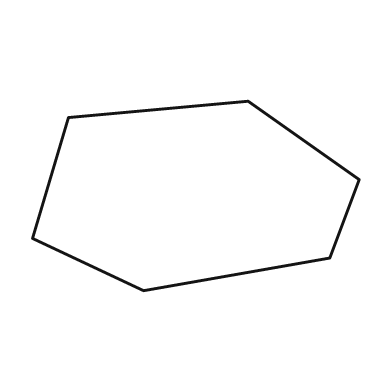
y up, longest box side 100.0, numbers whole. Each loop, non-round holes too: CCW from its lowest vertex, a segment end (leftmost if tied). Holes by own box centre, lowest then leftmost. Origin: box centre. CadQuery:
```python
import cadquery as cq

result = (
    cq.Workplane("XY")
    .moveTo(-16.0, -29.0)
    .lineTo(41.0, -19.0)
    .lineTo(50.0, 5.0)
    .lineTo(16.0, 29.0)
    .lineTo(-39.0, 24.0)
    .lineTo(-50.0, -13.0)
    .close()
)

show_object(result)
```